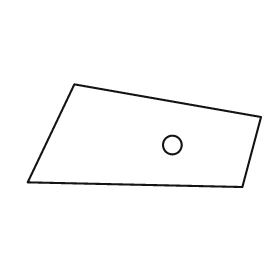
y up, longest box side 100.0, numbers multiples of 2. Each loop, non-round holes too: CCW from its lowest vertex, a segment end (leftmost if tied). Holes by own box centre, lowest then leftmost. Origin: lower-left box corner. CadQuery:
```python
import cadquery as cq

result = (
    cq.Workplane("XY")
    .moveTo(92.0, 0.0)
    .lineTo(100.0, 30.0)
    .lineTo(20.0, 44.0)
    .lineTo(0.0, 2.0)
    .close()
    .moveTo(62.0, 18.0)
    .circle(4.0)
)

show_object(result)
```